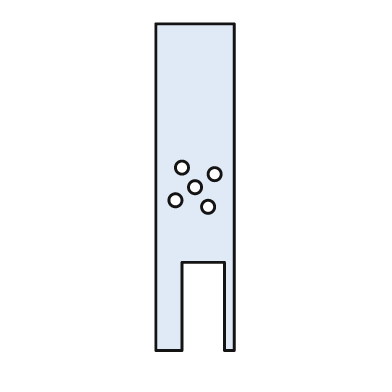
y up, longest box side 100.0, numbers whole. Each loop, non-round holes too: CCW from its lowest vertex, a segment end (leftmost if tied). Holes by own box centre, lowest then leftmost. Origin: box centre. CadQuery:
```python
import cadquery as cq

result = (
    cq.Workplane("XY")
    .moveTo(-12.0, -50.0)
    .lineTo(-4.0, -50.0)
    .lineTo(-4.0, -23.0)
    .lineTo(9.0, -23.0)
    .lineTo(9.0, -50.0)
    .lineTo(12.0, -50.0)
    .lineTo(12.0, 50.0)
    .lineTo(-12.0, 50.0)
    .close()
    .moveTo(4.0, -6.0)
    .circle(2.0)
    .moveTo(-6.0, -4.0)
    .circle(2.0)
    .moveTo(0.0, 0.0)
    .circle(2.0)
    .moveTo(6.0, 4.0)
    .circle(2.0)
    .moveTo(-4.0, 6.0)
    .circle(2.0)
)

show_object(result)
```